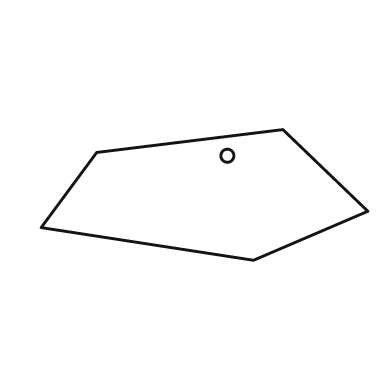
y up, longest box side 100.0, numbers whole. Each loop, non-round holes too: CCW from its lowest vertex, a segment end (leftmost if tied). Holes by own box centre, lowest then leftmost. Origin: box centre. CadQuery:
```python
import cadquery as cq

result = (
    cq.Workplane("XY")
    .moveTo(15.0, -20.0)
    .lineTo(50.0, -5.0)
    .lineTo(24.0, 20.0)
    .lineTo(-33.0, 13.0)
    .lineTo(-50.0, -10.0)
    .close()
    .moveTo(7.0, 12.0)
    .circle(2.0)
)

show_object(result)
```